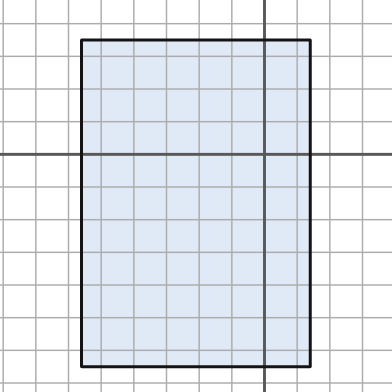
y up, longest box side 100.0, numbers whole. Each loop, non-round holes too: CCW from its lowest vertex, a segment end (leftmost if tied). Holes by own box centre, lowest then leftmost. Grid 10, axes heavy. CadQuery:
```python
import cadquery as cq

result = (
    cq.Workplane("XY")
    .moveTo(-56.0, -65.0)
    .lineTo(14.0, -65.0)
    .lineTo(14.0, 35.0)
    .lineTo(-56.0, 35.0)
    .close()
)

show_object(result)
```